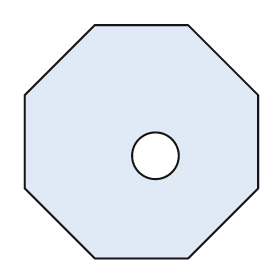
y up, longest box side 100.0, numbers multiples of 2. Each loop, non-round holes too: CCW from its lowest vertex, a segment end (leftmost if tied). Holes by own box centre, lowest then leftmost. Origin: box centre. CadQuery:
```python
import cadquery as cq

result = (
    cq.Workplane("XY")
    .moveTo(-20.0, -50.0)
    .lineTo(20.0, -50.0)
    .lineTo(50.0, -20.0)
    .lineTo(50.0, 20.0)
    .lineTo(20.0, 50.0)
    .lineTo(-20.0, 50.0)
    .lineTo(-50.0, 20.0)
    .lineTo(-50.0, -20.0)
    .close()
    .moveTo(6.0, -6.0)
    .circle(10.0)
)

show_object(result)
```